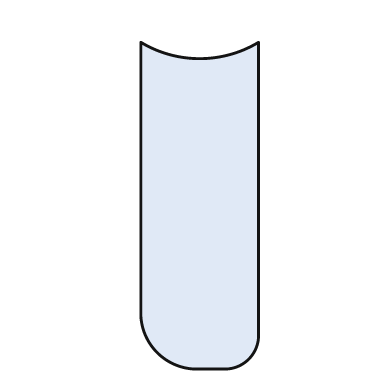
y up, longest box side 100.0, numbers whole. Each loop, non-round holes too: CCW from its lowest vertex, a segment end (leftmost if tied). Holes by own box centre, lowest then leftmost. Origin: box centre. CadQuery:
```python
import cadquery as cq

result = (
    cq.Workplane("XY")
    .moveTo(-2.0, -50.0)
    .lineTo(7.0, -50.0)
    .threePointArc((15.0, -47.0), (18.0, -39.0))
    .lineTo(18.0, 50.0)
    .threePointArc((0.0, 45.0), (-18.0, 50.0))
    .lineTo(-18.0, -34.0)
    .threePointArc((-13.0, -45.0), (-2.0, -50.0))
    .close()
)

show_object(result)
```